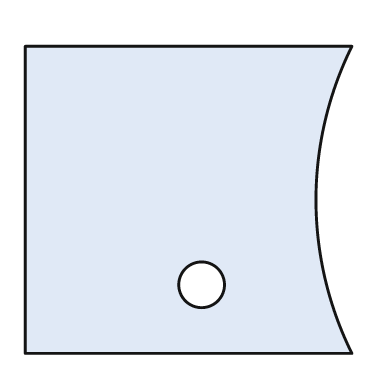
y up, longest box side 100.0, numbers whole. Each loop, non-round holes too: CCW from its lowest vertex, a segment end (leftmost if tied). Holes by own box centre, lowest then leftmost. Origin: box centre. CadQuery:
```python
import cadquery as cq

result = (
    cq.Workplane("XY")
    .moveTo(-50.0, -47.0)
    .lineTo(50.0, -47.0)
    .threePointArc((39.0, 0.0), (50.0, 47.0))
    .lineTo(-50.0, 47.0)
    .close()
    .moveTo(4.0, -26.0)
    .circle(7.0)
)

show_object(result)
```